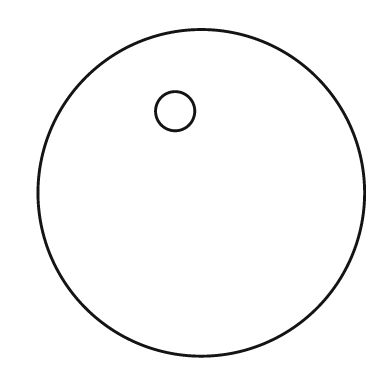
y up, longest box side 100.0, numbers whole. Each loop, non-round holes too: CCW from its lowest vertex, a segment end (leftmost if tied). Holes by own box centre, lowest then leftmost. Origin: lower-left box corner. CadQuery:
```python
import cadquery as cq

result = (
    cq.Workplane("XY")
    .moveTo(50.0, 50.0)
    .circle(50.0)
    .moveTo(42.0, 75.0)
    .circle(6.0)
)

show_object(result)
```